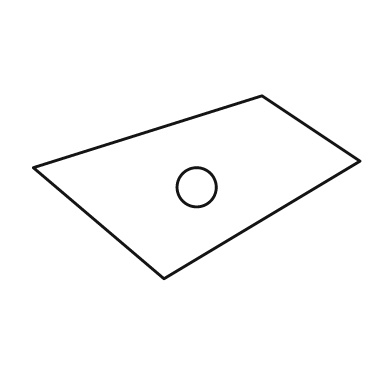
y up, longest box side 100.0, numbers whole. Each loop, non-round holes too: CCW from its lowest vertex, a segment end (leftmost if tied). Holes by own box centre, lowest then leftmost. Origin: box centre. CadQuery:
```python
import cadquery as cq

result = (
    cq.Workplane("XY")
    .moveTo(-10.0, -28.0)
    .lineTo(50.0, 8.0)
    .lineTo(20.0, 28.0)
    .lineTo(-50.0, 6.0)
    .close()
    .moveTo(0.0, 0.0)
    .circle(6.0)
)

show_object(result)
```